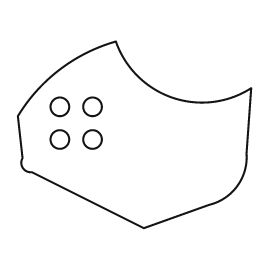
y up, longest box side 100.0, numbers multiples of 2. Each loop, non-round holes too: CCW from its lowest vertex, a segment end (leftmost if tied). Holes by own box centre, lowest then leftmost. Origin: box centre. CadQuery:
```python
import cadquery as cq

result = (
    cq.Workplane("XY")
    .moveTo(4.0, -40.0)
    .lineTo(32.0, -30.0)
    .threePointArc((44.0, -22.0), (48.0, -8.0))
    .lineTo(50.0, 20.0)
    .threePointArc((16.0, 16.0), (-8.0, 40.0))
    .threePointArc((-32.0, 28.0), (-50.0, 8.0))
    .lineTo(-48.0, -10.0)
    .threePointArc((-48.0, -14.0), (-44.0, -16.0))
    .close()
    .moveTo(-32.0, -2.0)
    .circle(4.0)
    .moveTo(-18.0, -2.0)
    .circle(4.0)
    .moveTo(-32.0, 12.0)
    .circle(4.0)
    .moveTo(-18.0, 12.0)
    .circle(4.0)
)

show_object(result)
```